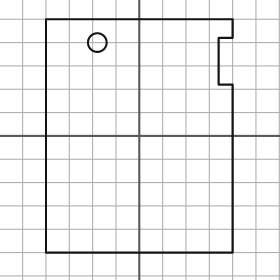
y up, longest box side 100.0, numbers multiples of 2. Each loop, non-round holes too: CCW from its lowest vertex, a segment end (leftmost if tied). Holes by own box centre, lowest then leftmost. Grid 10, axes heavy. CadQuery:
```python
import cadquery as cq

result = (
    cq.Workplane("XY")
    .moveTo(-40.0, -50.0)
    .lineTo(40.0, -50.0)
    .lineTo(40.0, 22.0)
    .lineTo(34.0, 22.0)
    .lineTo(34.0, 42.0)
    .lineTo(40.0, 42.0)
    .lineTo(40.0, 50.0)
    .lineTo(-40.0, 50.0)
    .close()
    .moveTo(-18.0, 40.0)
    .circle(4.0)
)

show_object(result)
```